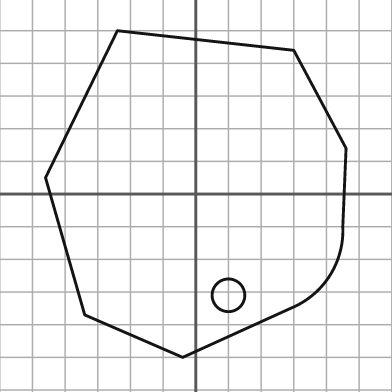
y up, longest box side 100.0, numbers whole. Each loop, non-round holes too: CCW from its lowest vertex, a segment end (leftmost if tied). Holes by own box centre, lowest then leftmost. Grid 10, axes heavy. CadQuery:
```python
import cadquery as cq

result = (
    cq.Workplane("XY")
    .moveTo(-4.0, -50.0)
    .lineTo(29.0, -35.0)
    .threePointArc((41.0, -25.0), (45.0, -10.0))
    .lineTo(46.0, 14.0)
    .lineTo(30.0, 44.0)
    .lineTo(-24.0, 50.0)
    .lineTo(-46.0, 5.0)
    .lineTo(-34.0, -37.0)
    .close()
    .moveTo(10.0, -31.0)
    .circle(5.0)
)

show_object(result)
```